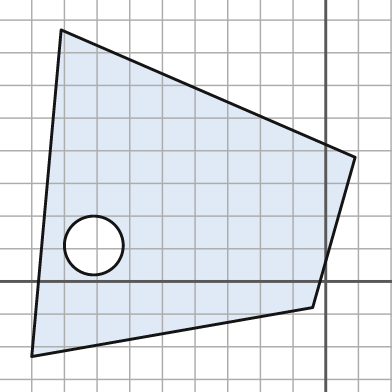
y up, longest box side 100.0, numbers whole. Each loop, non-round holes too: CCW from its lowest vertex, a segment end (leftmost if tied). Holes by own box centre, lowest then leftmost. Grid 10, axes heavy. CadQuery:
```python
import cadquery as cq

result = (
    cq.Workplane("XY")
    .moveTo(-90.0, -23.0)
    .lineTo(-4.0, -8.0)
    .lineTo(9.0, 38.0)
    .lineTo(-81.0, 77.0)
    .close()
    .moveTo(-71.0, 11.0)
    .circle(9.0)
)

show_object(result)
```